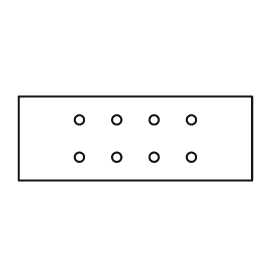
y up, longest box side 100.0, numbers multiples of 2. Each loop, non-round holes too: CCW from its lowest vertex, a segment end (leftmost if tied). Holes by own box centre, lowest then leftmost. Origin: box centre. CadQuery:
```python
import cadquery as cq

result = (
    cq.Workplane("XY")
    .moveTo(-50.0, -18.0)
    .lineTo(50.0, -18.0)
    .lineTo(50.0, 18.0)
    .lineTo(-50.0, 18.0)
    .close()
    .moveTo(-24.0, -8.0)
    .circle(2.0)
    .moveTo(-8.0, -8.0)
    .circle(2.0)
    .moveTo(8.0, -8.0)
    .circle(2.0)
    .moveTo(24.0, -8.0)
    .circle(2.0)
    .moveTo(-24.0, 8.0)
    .circle(2.0)
    .moveTo(-8.0, 8.0)
    .circle(2.0)
    .moveTo(8.0, 8.0)
    .circle(2.0)
    .moveTo(24.0, 8.0)
    .circle(2.0)
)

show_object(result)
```